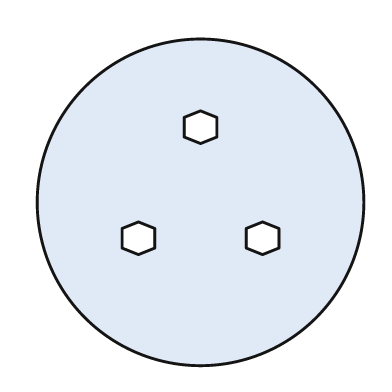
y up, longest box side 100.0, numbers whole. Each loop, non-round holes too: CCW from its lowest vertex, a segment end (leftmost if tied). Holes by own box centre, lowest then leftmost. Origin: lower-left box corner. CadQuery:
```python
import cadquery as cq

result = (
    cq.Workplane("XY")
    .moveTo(50.0, 50.0)
    .circle(50.0)
    .moveTo(31.0, 34.0)
    .lineTo(36.0, 36.0)
    .lineTo(36.0, 42.0)
    .lineTo(31.0, 44.0)
    .lineTo(26.0, 42.0)
    .lineTo(26.0, 36.0)
    .close()
    .moveTo(69.0, 34.0)
    .lineTo(74.0, 36.0)
    .lineTo(74.0, 42.0)
    .lineTo(69.0, 44.0)
    .lineTo(64.0, 42.0)
    .lineTo(64.0, 36.0)
    .close()
    .moveTo(50.0, 68.0)
    .lineTo(55.0, 70.0)
    .lineTo(55.0, 76.0)
    .lineTo(50.0, 78.0)
    .lineTo(45.0, 76.0)
    .lineTo(45.0, 70.0)
    .close()
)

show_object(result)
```